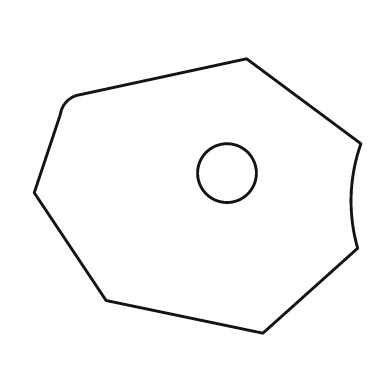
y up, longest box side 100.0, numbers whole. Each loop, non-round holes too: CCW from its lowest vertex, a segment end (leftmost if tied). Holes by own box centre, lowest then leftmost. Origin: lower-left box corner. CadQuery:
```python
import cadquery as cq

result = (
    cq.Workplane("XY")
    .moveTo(70.0, 0.0)
    .lineTo(99.0, 26.0)
    .threePointArc((97.0, 42.0), (100.0, 58.0))
    .lineTo(65.0, 84.0)
    .lineTo(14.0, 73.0)
    .threePointArc((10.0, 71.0), (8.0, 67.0))
    .lineTo(0.0, 43.0)
    .lineTo(22.0, 10.0)
    .close()
    .moveTo(59.0, 49.0)
    .circle(9.0)
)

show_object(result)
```